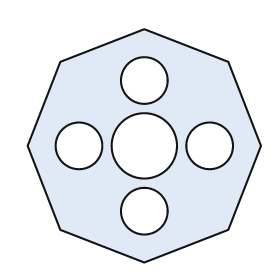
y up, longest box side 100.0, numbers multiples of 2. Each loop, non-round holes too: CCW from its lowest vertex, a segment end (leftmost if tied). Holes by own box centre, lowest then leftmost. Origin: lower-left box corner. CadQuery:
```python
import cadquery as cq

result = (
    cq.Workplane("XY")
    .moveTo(50.0, 0.0)
    .lineTo(86.0, 14.0)
    .lineTo(100.0, 50.0)
    .lineTo(86.0, 86.0)
    .lineTo(50.0, 100.0)
    .lineTo(14.0, 86.0)
    .lineTo(0.0, 50.0)
    .lineTo(14.0, 14.0)
    .close()
    .moveTo(50.0, 22.0)
    .circle(10.0)
    .moveTo(22.0, 50.0)
    .circle(10.0)
    .moveTo(50.0, 50.0)
    .circle(14.0)
    .moveTo(78.0, 50.0)
    .circle(10.0)
    .moveTo(50.0, 78.0)
    .circle(10.0)
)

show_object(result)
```